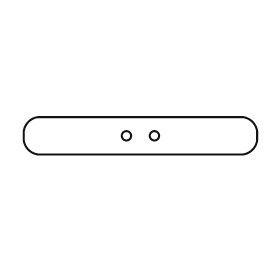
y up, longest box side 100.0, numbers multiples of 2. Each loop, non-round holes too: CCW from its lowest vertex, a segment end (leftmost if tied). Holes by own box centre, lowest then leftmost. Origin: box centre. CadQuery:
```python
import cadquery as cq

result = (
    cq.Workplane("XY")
    .moveTo(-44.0, -8.0)
    .lineTo(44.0, -8.0)
    .threePointArc((48.0, -6.0), (50.0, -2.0))
    .lineTo(50.0, 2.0)
    .threePointArc((48.0, 6.0), (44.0, 8.0))
    .lineTo(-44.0, 8.0)
    .threePointArc((-48.0, 6.0), (-50.0, 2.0))
    .lineTo(-50.0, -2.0)
    .threePointArc((-48.0, -6.0), (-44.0, -8.0))
    .close()
    .moveTo(-6.0, 0.0)
    .circle(2.0)
    .moveTo(6.0, 0.0)
    .circle(2.0)
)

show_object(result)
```